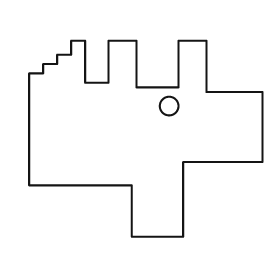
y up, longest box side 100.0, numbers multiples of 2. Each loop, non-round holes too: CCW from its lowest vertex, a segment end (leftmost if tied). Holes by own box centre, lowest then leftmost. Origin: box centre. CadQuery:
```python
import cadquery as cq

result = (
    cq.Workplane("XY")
    .moveTo(-6.0, -42.0)
    .lineTo(16.0, -42.0)
    .lineTo(16.0, -10.0)
    .lineTo(50.0, -10.0)
    .lineTo(50.0, 20.0)
    .lineTo(26.0, 20.0)
    .lineTo(26.0, 42.0)
    .lineTo(14.0, 42.0)
    .lineTo(14.0, 22.0)
    .lineTo(-4.0, 22.0)
    .lineTo(-4.0, 42.0)
    .lineTo(-16.0, 42.0)
    .lineTo(-16.0, 24.0)
    .lineTo(-26.0, 24.0)
    .lineTo(-26.0, 42.0)
    .lineTo(-32.0, 42.0)
    .lineTo(-32.0, 36.0)
    .lineTo(-38.0, 36.0)
    .lineTo(-38.0, 32.0)
    .lineTo(-44.0, 32.0)
    .lineTo(-44.0, 28.0)
    .lineTo(-50.0, 28.0)
    .lineTo(-50.0, -20.0)
    .lineTo(-6.0, -20.0)
    .close()
    .moveTo(10.0, 14.0)
    .circle(4.0)
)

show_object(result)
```